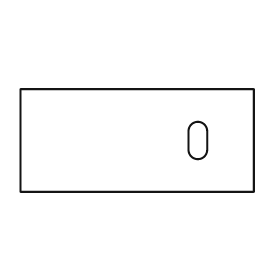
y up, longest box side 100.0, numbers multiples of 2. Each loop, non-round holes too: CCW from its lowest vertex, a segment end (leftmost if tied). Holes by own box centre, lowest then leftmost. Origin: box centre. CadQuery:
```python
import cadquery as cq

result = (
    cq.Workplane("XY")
    .moveTo(-50.0, -22.0)
    .lineTo(50.0, -22.0)
    .lineTo(50.0, 22.0)
    .lineTo(-50.0, 22.0)
    .close()
    .moveTo(22.0, -4.0)
    .threePointArc((26.0, -8.0), (30.0, -4.0))
    .lineTo(30.0, 4.0)
    .threePointArc((26.0, 8.0), (22.0, 4.0))
    .close()
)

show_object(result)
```